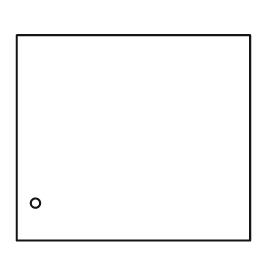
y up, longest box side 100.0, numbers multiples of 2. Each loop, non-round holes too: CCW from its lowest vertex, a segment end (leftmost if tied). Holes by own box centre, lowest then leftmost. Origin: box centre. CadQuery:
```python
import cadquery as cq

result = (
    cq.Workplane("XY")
    .moveTo(-50.0, -44.0)
    .lineTo(50.0, -44.0)
    .lineTo(50.0, 44.0)
    .lineTo(-50.0, 44.0)
    .close()
    .moveTo(-42.0, -28.0)
    .circle(2.0)
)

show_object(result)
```